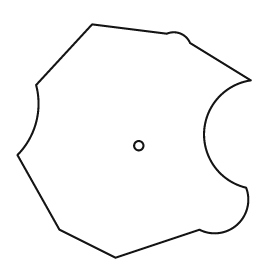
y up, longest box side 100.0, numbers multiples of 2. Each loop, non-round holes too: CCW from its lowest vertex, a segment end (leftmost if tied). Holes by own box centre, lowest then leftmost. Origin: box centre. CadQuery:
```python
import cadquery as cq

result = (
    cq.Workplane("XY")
    .moveTo(-8.0, -50.0)
    .lineTo(28.0, -38.0)
    .threePointArc((44.0, -36.0), (48.0, -20.0))
    .threePointArc((30.0, 4.0), (50.0, 26.0))
    .lineTo(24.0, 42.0)
    .threePointArc((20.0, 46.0), (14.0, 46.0))
    .lineTo(-18.0, 50.0)
    .lineTo(-42.0, 24.0)
    .threePointArc((-42.0, 8.0), (-50.0, -6.0))
    .lineTo(-32.0, -38.0)
    .close()
    .moveTo(2.0, -2.0)
    .circle(2.0)
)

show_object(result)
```